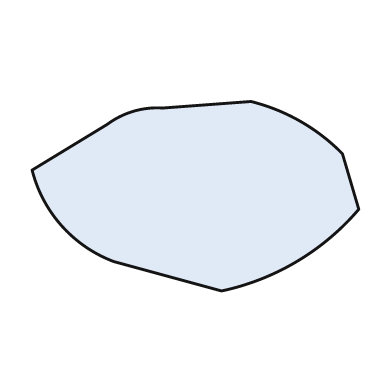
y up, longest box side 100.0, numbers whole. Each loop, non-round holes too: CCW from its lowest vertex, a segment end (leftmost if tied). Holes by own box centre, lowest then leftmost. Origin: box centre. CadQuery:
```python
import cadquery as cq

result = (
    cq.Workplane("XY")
    .moveTo(8.0, -29.0)
    .threePointArc((31.0, -20.0), (50.0, -4.0))
    .lineTo(45.0, 13.0)
    .threePointArc((32.0, 23.0), (17.0, 29.0))
    .lineTo(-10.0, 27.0)
    .threePointArc((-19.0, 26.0), (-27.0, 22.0))
    .lineTo(-50.0, 8.0)
    .threePointArc((-41.0, -9.0), (-25.0, -20.0))
    .close()
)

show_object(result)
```